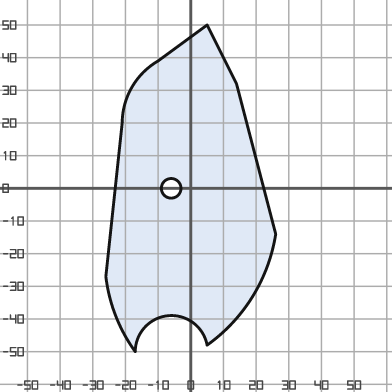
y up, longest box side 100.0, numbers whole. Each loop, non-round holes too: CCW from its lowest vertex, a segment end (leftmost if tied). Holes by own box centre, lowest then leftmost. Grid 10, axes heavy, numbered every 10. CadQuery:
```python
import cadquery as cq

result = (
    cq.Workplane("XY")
    .moveTo(-17.0, -50.0)
    .threePointArc((-7.0, -39.0), (5.0, -48.0))
    .threePointArc((19.0, -33.0), (26.0, -14.0))
    .lineTo(14.0, 32.0)
    .lineTo(5.0, 50.0)
    .lineTo(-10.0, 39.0)
    .threePointArc((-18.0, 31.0), (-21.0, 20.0))
    .lineTo(-26.0, -27.0)
    .threePointArc((-23.0, -39.0), (-17.0, -50.0))
    .close()
    .moveTo(-6.0, 0.0)
    .circle(3.0)
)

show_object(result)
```